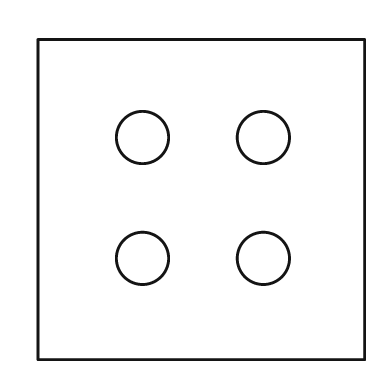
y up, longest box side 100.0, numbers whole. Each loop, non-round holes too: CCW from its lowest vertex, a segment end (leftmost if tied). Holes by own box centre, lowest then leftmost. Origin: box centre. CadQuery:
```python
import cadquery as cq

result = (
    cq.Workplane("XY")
    .moveTo(-50.0, -49.0)
    .lineTo(50.0, -49.0)
    .lineTo(50.0, 49.0)
    .lineTo(-50.0, 49.0)
    .close()
    .moveTo(-18.0, -18.0)
    .circle(8.0)
    .moveTo(19.0, -18.0)
    .circle(8.0)
    .moveTo(-18.0, 19.0)
    .circle(8.0)
    .moveTo(19.0, 19.0)
    .circle(8.0)
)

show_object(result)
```